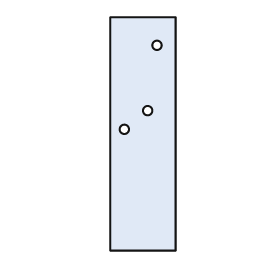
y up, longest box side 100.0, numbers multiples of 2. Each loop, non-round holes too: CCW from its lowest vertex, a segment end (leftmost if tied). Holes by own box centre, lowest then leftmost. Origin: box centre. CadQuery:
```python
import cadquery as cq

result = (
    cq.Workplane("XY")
    .moveTo(-14.0, -50.0)
    .lineTo(14.0, -50.0)
    .lineTo(14.0, 50.0)
    .lineTo(-14.0, 50.0)
    .close()
    .moveTo(-8.0, 2.0)
    .circle(2.0)
    .moveTo(2.0, 10.0)
    .circle(2.0)
    .moveTo(6.0, 38.0)
    .circle(2.0)
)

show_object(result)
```